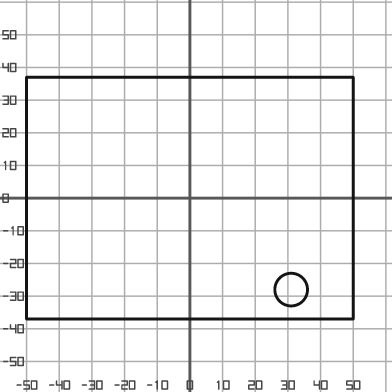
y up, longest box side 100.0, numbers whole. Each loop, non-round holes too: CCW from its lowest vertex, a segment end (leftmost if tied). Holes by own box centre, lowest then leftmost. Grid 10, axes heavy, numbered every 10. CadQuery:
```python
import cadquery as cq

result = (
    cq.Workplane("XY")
    .moveTo(-50.0, -37.0)
    .lineTo(50.0, -37.0)
    .lineTo(50.0, 37.0)
    .lineTo(-50.0, 37.0)
    .close()
    .moveTo(31.0, -28.0)
    .circle(5.0)
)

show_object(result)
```